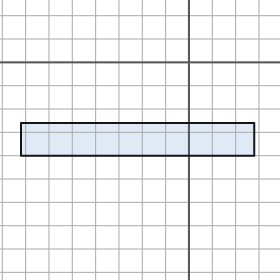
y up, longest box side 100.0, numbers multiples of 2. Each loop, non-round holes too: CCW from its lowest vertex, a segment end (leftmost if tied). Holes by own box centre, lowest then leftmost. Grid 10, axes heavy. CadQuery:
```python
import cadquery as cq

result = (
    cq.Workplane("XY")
    .moveTo(-72.0, -40.0)
    .lineTo(28.0, -40.0)
    .lineTo(28.0, -26.0)
    .lineTo(-72.0, -26.0)
    .close()
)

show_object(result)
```